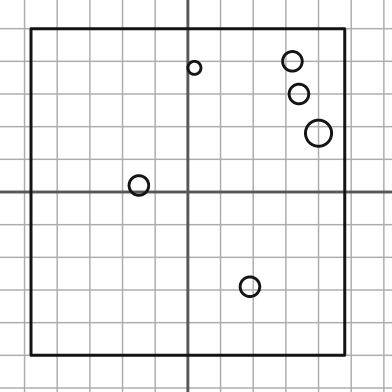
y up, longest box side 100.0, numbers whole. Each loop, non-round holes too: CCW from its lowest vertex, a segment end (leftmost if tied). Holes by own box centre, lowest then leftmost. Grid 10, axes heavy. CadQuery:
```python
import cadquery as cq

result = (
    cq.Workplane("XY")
    .moveTo(-48.0, -50.0)
    .lineTo(48.0, -50.0)
    .lineTo(48.0, 50.0)
    .lineTo(-48.0, 50.0)
    .close()
    .moveTo(19.0, -29.0)
    .circle(3.0)
    .moveTo(-15.0, 2.0)
    .circle(3.0)
    .moveTo(40.0, 18.0)
    .circle(4.0)
    .moveTo(34.0, 30.0)
    .circle(3.0)
    .moveTo(2.0, 38.0)
    .circle(2.0)
    .moveTo(32.0, 40.0)
    .circle(3.0)
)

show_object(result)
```